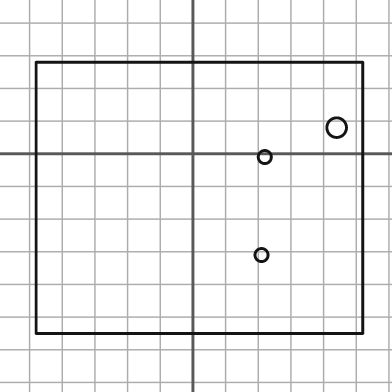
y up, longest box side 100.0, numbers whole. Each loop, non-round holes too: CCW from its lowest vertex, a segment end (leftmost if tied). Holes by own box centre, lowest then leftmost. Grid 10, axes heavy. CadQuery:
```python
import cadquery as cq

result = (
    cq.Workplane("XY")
    .moveTo(-48.0, -55.0)
    .lineTo(52.0, -55.0)
    .lineTo(52.0, 28.0)
    .lineTo(-48.0, 28.0)
    .close()
    .moveTo(21.0, -31.0)
    .circle(2.0)
    .moveTo(22.0, -1.0)
    .circle(2.0)
    .moveTo(44.0, 8.0)
    .circle(3.0)
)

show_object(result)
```